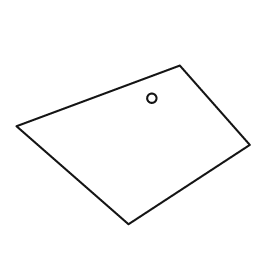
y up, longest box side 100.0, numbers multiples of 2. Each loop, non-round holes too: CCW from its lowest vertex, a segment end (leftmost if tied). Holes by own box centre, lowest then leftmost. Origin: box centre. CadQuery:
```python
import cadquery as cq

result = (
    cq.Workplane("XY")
    .moveTo(-2.0, -34.0)
    .lineTo(50.0, 0.0)
    .lineTo(20.0, 34.0)
    .lineTo(-50.0, 8.0)
    .close()
    .moveTo(8.0, 20.0)
    .circle(2.0)
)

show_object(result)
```